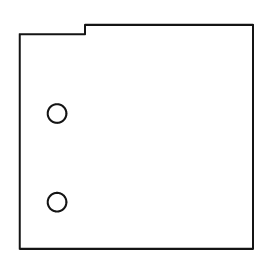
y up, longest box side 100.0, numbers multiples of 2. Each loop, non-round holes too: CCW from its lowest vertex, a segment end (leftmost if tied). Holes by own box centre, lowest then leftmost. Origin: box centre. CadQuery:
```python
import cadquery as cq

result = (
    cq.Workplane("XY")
    .moveTo(-50.0, -48.0)
    .lineTo(50.0, -48.0)
    .lineTo(50.0, 48.0)
    .lineTo(-22.0, 48.0)
    .lineTo(-22.0, 44.0)
    .lineTo(-50.0, 44.0)
    .close()
    .moveTo(-34.0, -28.0)
    .circle(4.0)
    .moveTo(-34.0, 10.0)
    .circle(4.0)
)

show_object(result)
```